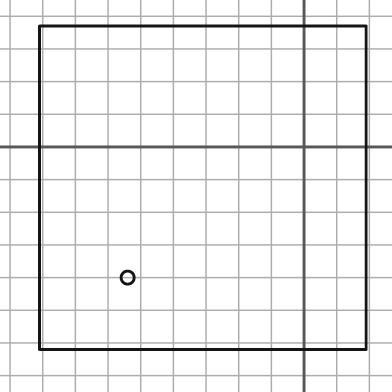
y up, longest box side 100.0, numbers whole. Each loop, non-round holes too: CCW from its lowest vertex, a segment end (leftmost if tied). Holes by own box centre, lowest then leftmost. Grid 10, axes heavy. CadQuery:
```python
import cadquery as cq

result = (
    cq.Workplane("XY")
    .moveTo(-81.0, -62.0)
    .lineTo(19.0, -62.0)
    .lineTo(19.0, 37.0)
    .lineTo(-81.0, 37.0)
    .close()
    .moveTo(-54.0, -40.0)
    .circle(2.0)
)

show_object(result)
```